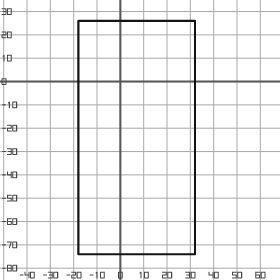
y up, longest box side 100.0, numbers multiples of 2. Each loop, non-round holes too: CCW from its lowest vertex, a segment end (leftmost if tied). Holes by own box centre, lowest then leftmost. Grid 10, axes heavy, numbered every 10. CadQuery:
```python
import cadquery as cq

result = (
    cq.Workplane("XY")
    .moveTo(-18.0, -74.0)
    .lineTo(32.0, -74.0)
    .lineTo(32.0, 26.0)
    .lineTo(-18.0, 26.0)
    .close()
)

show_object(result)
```